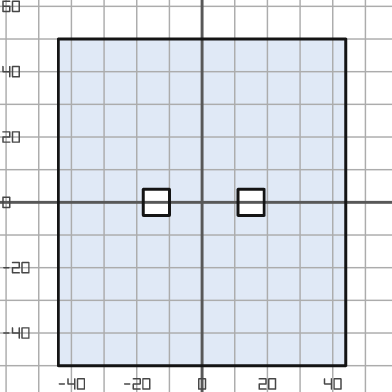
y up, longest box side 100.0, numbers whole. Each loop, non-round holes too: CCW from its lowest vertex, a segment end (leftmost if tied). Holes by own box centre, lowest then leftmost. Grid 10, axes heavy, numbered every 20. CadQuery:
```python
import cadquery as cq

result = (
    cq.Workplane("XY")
    .moveTo(-44.0, -50.0)
    .lineTo(44.0, -50.0)
    .lineTo(44.0, 50.0)
    .lineTo(-44.0, 50.0)
    .close()
    .moveTo(-18.0, -4.0)
    .lineTo(-10.0, -4.0)
    .lineTo(-10.0, 4.0)
    .lineTo(-18.0, 4.0)
    .close()
    .moveTo(11.0, -4.0)
    .lineTo(19.0, -4.0)
    .lineTo(19.0, 4.0)
    .lineTo(11.0, 4.0)
    .close()
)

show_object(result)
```